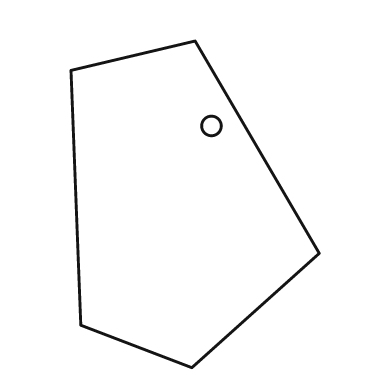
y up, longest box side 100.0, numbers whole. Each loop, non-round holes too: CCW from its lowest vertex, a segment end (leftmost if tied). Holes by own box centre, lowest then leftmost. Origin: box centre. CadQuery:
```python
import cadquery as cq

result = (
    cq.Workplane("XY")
    .moveTo(-1.0, -50.0)
    .lineTo(38.0, -15.0)
    .lineTo(0.0, 50.0)
    .lineTo(-38.0, 41.0)
    .lineTo(-35.0, -37.0)
    .close()
    .moveTo(5.0, 24.0)
    .circle(3.0)
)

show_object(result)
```